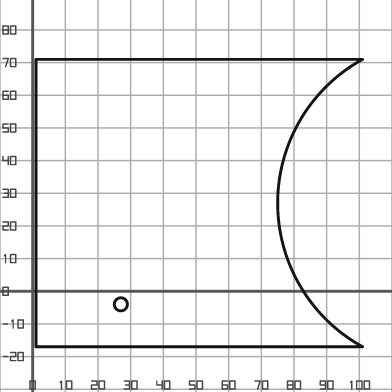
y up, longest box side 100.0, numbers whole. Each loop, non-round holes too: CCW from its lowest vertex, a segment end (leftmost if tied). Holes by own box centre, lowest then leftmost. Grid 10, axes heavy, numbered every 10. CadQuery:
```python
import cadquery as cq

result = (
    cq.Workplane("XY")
    .moveTo(1.0, -17.0)
    .lineTo(101.0, -17.0)
    .threePointArc((75.0, 27.0), (101.0, 71.0))
    .lineTo(1.0, 71.0)
    .close()
    .moveTo(27.0, -4.0)
    .circle(2.0)
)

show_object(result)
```